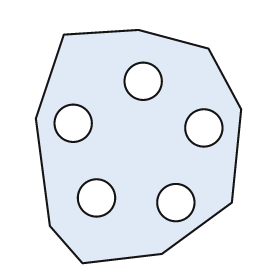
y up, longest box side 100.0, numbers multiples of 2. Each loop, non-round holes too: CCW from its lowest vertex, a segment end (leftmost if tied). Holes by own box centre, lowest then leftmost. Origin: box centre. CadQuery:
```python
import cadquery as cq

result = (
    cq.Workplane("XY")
    .moveTo(-24.0, -50.0)
    .lineTo(10.0, -46.0)
    .lineTo(40.0, -24.0)
    .lineTo(44.0, 16.0)
    .lineTo(30.0, 42.0)
    .lineTo(0.0, 50.0)
    .lineTo(-32.0, 48.0)
    .lineTo(-44.0, 12.0)
    .lineTo(-38.0, -34.0)
    .close()
    .moveTo(16.0, -24.0)
    .circle(8.0)
    .moveTo(-18.0, -22.0)
    .circle(8.0)
    .moveTo(28.0, 8.0)
    .circle(8.0)
    .moveTo(-28.0, 10.0)
    .circle(8.0)
    .moveTo(2.0, 28.0)
    .circle(8.0)
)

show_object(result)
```